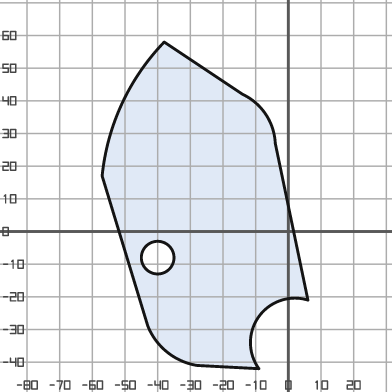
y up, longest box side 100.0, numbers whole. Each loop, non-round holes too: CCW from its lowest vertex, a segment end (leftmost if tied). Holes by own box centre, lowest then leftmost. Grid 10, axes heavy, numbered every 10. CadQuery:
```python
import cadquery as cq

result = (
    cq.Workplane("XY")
    .moveTo(-9.0, -42.0)
    .threePointArc((-9.0, -26.0), (6.0, -21.0))
    .lineTo(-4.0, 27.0)
    .threePointArc((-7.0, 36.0), (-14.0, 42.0))
    .lineTo(-38.0, 58.0)
    .threePointArc((-51.0, 39.0), (-57.0, 17.0))
    .lineTo(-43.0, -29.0)
    .threePointArc((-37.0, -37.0), (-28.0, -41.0))
    .close()
    .moveTo(-40.0, -8.0)
    .circle(5.0)
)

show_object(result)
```